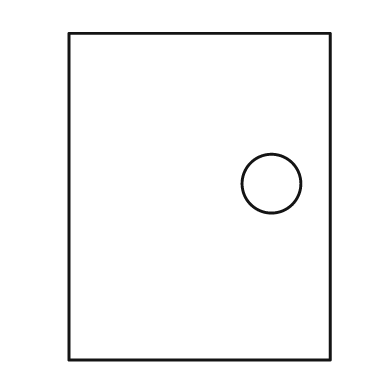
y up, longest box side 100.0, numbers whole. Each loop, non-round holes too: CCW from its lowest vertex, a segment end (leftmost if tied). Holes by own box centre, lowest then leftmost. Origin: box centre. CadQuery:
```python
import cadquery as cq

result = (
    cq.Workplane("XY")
    .moveTo(-40.0, -50.0)
    .lineTo(40.0, -50.0)
    .lineTo(40.0, 50.0)
    .lineTo(-40.0, 50.0)
    .close()
    .moveTo(22.0, 4.0)
    .circle(9.0)
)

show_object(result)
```